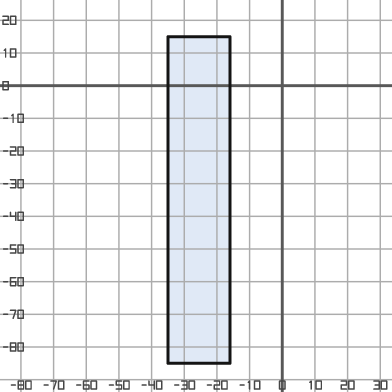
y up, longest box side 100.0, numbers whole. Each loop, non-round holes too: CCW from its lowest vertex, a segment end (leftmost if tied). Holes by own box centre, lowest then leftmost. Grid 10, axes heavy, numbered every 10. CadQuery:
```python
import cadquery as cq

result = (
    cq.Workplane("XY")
    .moveTo(-35.0, -85.0)
    .lineTo(-16.0, -85.0)
    .lineTo(-16.0, 15.0)
    .lineTo(-35.0, 15.0)
    .close()
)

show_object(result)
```